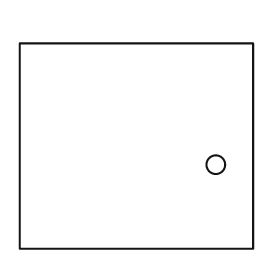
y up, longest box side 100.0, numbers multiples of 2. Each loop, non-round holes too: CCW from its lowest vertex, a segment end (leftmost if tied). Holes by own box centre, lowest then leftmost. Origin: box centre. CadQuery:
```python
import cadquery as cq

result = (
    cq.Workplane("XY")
    .moveTo(-50.0, -44.0)
    .lineTo(50.0, -44.0)
    .lineTo(50.0, 44.0)
    .lineTo(-50.0, 44.0)
    .close()
    .moveTo(34.0, -8.0)
    .circle(4.0)
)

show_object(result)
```